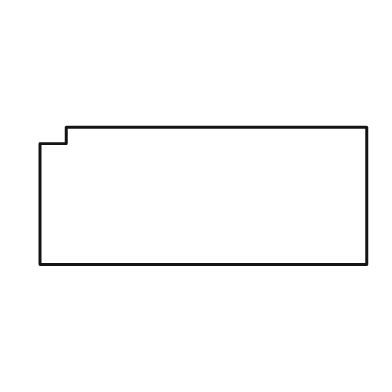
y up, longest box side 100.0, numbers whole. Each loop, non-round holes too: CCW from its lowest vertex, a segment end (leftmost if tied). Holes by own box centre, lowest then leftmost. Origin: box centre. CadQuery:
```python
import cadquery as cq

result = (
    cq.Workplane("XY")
    .moveTo(-50.0, -21.0)
    .lineTo(50.0, -21.0)
    .lineTo(50.0, 21.0)
    .lineTo(-42.0, 21.0)
    .lineTo(-42.0, 16.0)
    .lineTo(-50.0, 16.0)
    .close()
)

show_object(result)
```